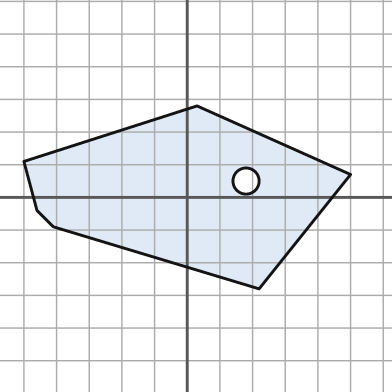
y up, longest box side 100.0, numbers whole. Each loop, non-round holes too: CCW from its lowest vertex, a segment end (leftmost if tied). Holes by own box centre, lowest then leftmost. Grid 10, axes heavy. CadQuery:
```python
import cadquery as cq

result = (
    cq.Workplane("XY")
    .moveTo(22.0, -28.0)
    .lineTo(50.0, 7.0)
    .lineTo(3.0, 28.0)
    .lineTo(-50.0, 11.0)
    .lineTo(-46.0, -4.0)
    .lineTo(-41.0, -9.0)
    .close()
    .moveTo(18.0, 5.0)
    .circle(4.0)
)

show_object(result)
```